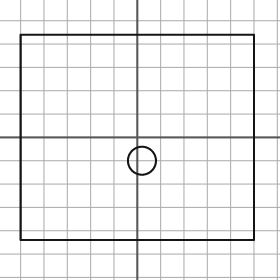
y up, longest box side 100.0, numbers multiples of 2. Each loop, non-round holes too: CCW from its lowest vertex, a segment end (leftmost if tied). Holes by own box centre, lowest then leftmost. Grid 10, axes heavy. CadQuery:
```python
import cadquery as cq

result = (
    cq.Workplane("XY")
    .moveTo(-50.0, -44.0)
    .lineTo(50.0, -44.0)
    .lineTo(50.0, 44.0)
    .lineTo(-50.0, 44.0)
    .close()
    .moveTo(2.0, -10.0)
    .circle(6.0)
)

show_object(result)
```